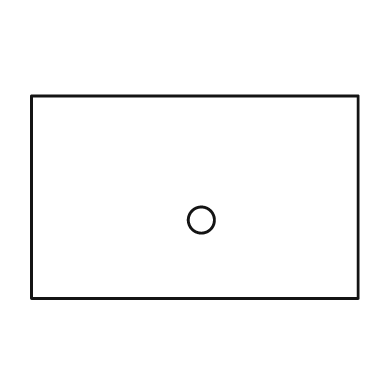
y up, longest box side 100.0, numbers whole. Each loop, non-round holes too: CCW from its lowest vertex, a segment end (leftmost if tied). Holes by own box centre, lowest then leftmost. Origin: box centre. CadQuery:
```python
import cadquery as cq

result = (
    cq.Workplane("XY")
    .moveTo(-50.0, -31.0)
    .lineTo(50.0, -31.0)
    .lineTo(50.0, 31.0)
    .lineTo(-50.0, 31.0)
    .close()
    .moveTo(2.0, -7.0)
    .circle(4.0)
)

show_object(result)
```